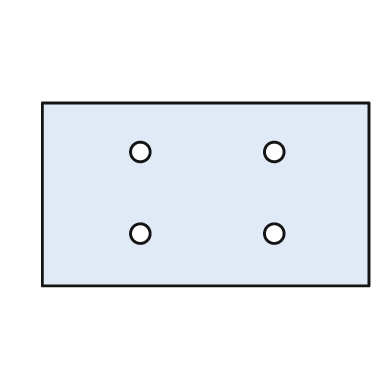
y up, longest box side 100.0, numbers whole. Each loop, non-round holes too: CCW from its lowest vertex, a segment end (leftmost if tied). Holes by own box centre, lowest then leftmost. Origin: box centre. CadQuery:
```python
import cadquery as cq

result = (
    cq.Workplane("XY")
    .moveTo(-50.0, -28.0)
    .lineTo(50.0, -28.0)
    .lineTo(50.0, 28.0)
    .lineTo(-50.0, 28.0)
    .close()
    .moveTo(-20.0, -12.0)
    .circle(3.0)
    .moveTo(21.0, -12.0)
    .circle(3.0)
    .moveTo(-20.0, 13.0)
    .circle(3.0)
    .moveTo(21.0, 13.0)
    .circle(3.0)
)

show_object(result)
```